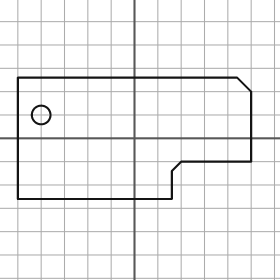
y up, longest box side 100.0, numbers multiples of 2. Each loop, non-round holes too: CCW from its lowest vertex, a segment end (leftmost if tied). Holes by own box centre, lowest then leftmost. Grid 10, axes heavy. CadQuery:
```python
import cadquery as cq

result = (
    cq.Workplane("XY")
    .moveTo(-50.0, -26.0)
    .lineTo(16.0, -26.0)
    .lineTo(16.0, -14.0)
    .lineTo(20.0, -10.0)
    .lineTo(50.0, -10.0)
    .lineTo(50.0, 20.0)
    .lineTo(44.0, 26.0)
    .lineTo(-50.0, 26.0)
    .close()
    .moveTo(-40.0, 10.0)
    .circle(4.0)
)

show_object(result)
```